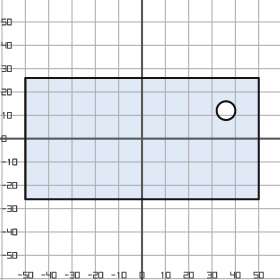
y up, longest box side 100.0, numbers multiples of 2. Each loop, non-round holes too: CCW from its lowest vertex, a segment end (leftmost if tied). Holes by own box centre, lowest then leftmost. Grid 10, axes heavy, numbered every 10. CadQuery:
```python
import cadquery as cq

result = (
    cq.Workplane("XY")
    .moveTo(-50.0, -26.0)
    .lineTo(50.0, -26.0)
    .lineTo(50.0, 26.0)
    .lineTo(-50.0, 26.0)
    .close()
    .moveTo(36.0, 12.0)
    .circle(4.0)
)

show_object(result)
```